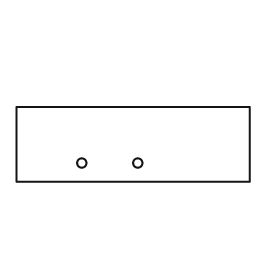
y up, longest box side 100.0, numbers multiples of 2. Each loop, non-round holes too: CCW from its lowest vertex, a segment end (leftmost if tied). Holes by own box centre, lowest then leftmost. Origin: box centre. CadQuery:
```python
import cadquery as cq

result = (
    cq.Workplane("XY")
    .moveTo(-50.0, -16.0)
    .lineTo(50.0, -16.0)
    .lineTo(50.0, 16.0)
    .lineTo(-50.0, 16.0)
    .close()
    .moveTo(-22.0, -8.0)
    .circle(2.0)
    .moveTo(2.0, -8.0)
    .circle(2.0)
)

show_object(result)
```